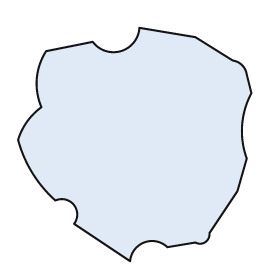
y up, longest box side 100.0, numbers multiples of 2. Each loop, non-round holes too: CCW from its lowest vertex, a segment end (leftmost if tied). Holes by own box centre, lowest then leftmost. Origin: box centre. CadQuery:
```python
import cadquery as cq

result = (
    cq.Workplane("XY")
    .moveTo(-2.0, -50.0)
    .threePointArc((4.0, -42.0), (14.0, -44.0))
    .lineTo(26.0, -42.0)
    .threePointArc((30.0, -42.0), (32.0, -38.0))
    .lineTo(44.0, -20.0)
    .lineTo(48.0, -6.0)
    .threePointArc((46.0, 8.0), (50.0, 22.0))
    .lineTo(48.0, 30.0)
    .threePointArc((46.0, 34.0), (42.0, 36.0))
    .lineTo(26.0, 46.0)
    .lineTo(2.0, 50.0)
    .threePointArc((-6.0, 40.0), (-18.0, 44.0))
    .lineTo(-38.0, 40.0)
    .threePointArc((-42.0, 28.0), (-40.0, 16.0))
    .threePointArc((-46.0, 10.0), (-50.0, 2.0))
    .threePointArc((-44.0, -12.0), (-34.0, -24.0))
    .threePointArc((-26.0, -26.0), (-26.0, -34.0))
    .close()
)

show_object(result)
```